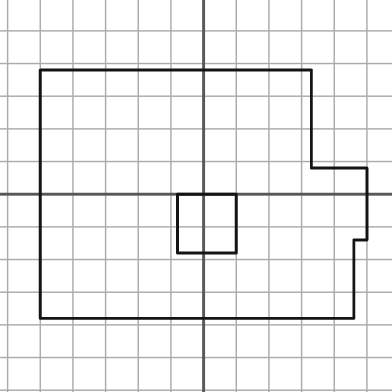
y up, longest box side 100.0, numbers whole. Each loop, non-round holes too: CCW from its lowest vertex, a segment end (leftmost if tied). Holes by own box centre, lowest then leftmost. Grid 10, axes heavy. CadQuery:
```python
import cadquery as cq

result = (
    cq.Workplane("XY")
    .moveTo(-50.0, -38.0)
    .lineTo(46.0, -38.0)
    .lineTo(46.0, -14.0)
    .lineTo(50.0, -14.0)
    .lineTo(50.0, 8.0)
    .lineTo(33.0, 8.0)
    .lineTo(33.0, 38.0)
    .lineTo(-50.0, 38.0)
    .close()
    .moveTo(-8.0, -18.0)
    .lineTo(10.0, -18.0)
    .lineTo(10.0, 0.0)
    .lineTo(-8.0, 0.0)
    .close()
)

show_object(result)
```